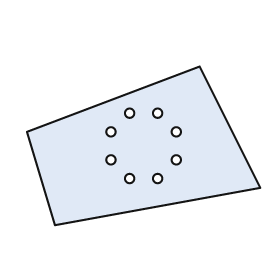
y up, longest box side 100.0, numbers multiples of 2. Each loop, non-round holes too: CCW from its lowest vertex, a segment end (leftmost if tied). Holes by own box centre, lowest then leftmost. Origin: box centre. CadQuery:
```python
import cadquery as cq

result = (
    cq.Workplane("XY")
    .moveTo(-38.0, -34.0)
    .lineTo(50.0, -18.0)
    .lineTo(24.0, 34.0)
    .lineTo(-50.0, 6.0)
    .close()
    .moveTo(-6.0, -14.0)
    .circle(2.0)
    .moveTo(6.0, -14.0)
    .circle(2.0)
    .moveTo(-14.0, -6.0)
    .circle(2.0)
    .moveTo(14.0, -6.0)
    .circle(2.0)
    .moveTo(-14.0, 6.0)
    .circle(2.0)
    .moveTo(14.0, 6.0)
    .circle(2.0)
    .moveTo(-6.0, 14.0)
    .circle(2.0)
    .moveTo(6.0, 14.0)
    .circle(2.0)
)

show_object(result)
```